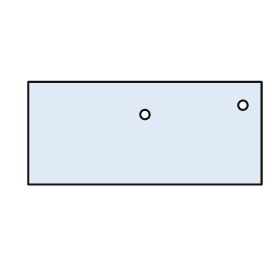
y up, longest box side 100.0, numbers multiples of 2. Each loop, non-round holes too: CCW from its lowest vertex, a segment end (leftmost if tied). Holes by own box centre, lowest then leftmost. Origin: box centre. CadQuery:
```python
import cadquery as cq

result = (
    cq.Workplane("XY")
    .moveTo(-50.0, -22.0)
    .lineTo(50.0, -22.0)
    .lineTo(50.0, 22.0)
    .lineTo(-50.0, 22.0)
    .close()
    .moveTo(0.0, 8.0)
    .circle(2.0)
    .moveTo(42.0, 12.0)
    .circle(2.0)
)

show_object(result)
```